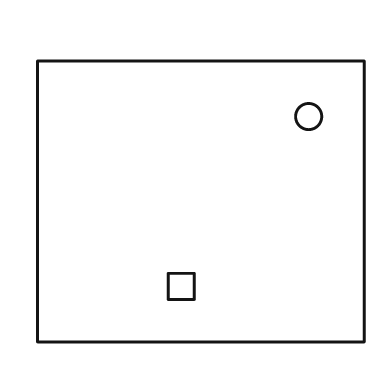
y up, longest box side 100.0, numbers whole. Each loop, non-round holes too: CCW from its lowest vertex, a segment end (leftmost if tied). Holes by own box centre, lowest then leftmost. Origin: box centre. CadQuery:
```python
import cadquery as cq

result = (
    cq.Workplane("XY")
    .moveTo(-50.0, -43.0)
    .lineTo(50.0, -43.0)
    .lineTo(50.0, 43.0)
    .lineTo(-50.0, 43.0)
    .close()
    .moveTo(-10.0, -30.0)
    .lineTo(-2.0, -30.0)
    .lineTo(-2.0, -22.0)
    .lineTo(-10.0, -22.0)
    .close()
    .moveTo(33.0, 26.0)
    .circle(4.0)
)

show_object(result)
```